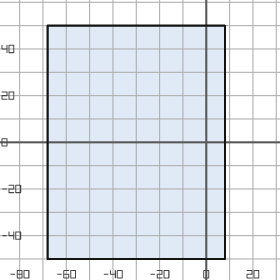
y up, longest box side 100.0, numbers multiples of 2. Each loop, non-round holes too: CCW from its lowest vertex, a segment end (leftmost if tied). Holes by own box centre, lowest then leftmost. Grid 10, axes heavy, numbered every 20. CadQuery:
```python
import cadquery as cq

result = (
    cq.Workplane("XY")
    .moveTo(-68.0, -50.0)
    .lineTo(8.0, -50.0)
    .lineTo(8.0, 50.0)
    .lineTo(-68.0, 50.0)
    .close()
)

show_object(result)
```